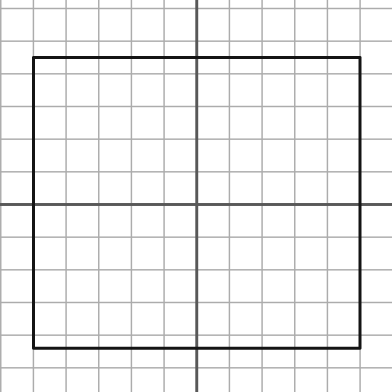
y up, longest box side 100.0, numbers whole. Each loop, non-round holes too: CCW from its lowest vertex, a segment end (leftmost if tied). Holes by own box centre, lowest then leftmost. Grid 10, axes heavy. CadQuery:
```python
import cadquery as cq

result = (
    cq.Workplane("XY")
    .moveTo(-50.0, -44.0)
    .lineTo(50.0, -44.0)
    .lineTo(50.0, 45.0)
    .lineTo(-50.0, 45.0)
    .close()
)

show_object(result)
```